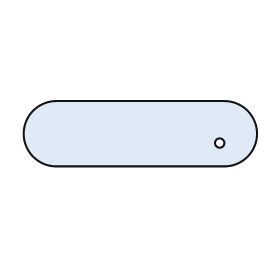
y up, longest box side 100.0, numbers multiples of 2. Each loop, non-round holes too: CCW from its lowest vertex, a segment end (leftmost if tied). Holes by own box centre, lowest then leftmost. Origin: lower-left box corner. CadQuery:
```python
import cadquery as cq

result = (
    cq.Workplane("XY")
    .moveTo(14.0, 0.0)
    .lineTo(86.0, 0.0)
    .threePointArc((100.0, 14.0), (86.0, 28.0))
    .lineTo(14.0, 28.0)
    .threePointArc((0.0, 14.0), (14.0, 0.0))
    .close()
    .moveTo(84.0, 10.0)
    .circle(2.0)
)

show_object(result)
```